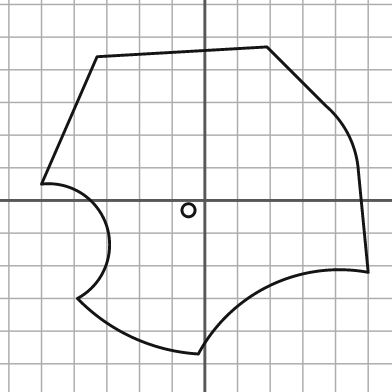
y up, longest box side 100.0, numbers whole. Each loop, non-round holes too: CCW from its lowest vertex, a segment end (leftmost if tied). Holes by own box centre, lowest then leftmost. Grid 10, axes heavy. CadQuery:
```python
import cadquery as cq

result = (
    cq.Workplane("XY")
    .moveTo(-2.0, -47.0)
    .threePointArc((20.0, -26.0), (50.0, -22.0))
    .lineTo(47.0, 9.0)
    .threePointArc((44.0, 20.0), (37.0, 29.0))
    .lineTo(19.0, 47.0)
    .lineTo(-33.0, 44.0)
    .lineTo(-50.0, 5.0)
    .threePointArc((-30.0, -8.0), (-39.0, -30.0))
    .threePointArc((-22.0, -42.0), (-2.0, -47.0))
    .close()
    .moveTo(-5.0, -3.0)
    .circle(2.0)
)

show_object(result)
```